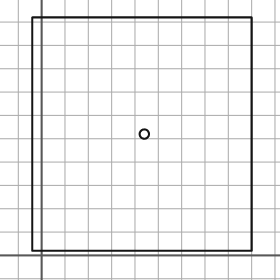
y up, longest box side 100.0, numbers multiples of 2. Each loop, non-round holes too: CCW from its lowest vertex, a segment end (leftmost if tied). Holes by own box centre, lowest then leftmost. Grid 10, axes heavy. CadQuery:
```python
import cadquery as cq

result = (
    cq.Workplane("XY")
    .moveTo(-4.0, 2.0)
    .lineTo(90.0, 2.0)
    .lineTo(90.0, 102.0)
    .lineTo(-4.0, 102.0)
    .close()
    .moveTo(44.0, 52.0)
    .circle(2.0)
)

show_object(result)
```